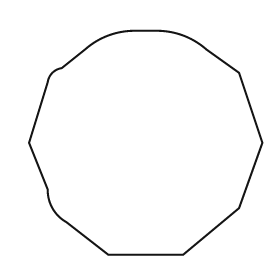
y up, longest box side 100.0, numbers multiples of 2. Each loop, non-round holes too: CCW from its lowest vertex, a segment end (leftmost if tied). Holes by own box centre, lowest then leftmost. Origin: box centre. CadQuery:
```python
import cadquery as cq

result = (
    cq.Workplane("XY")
    .moveTo(-16.0, -48.0)
    .lineTo(16.0, -48.0)
    .lineTo(40.0, -28.0)
    .lineTo(50.0, 0.0)
    .lineTo(40.0, 30.0)
    .lineTo(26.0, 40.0)
    .threePointArc((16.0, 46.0), (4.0, 48.0))
    .lineTo(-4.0, 48.0)
    .threePointArc((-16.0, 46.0), (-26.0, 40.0))
    .lineTo(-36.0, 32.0)
    .threePointArc((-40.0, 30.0), (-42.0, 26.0))
    .lineTo(-50.0, 0.0)
    .lineTo(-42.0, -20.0)
    .threePointArc((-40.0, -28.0), (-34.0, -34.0))
    .close()
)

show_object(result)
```